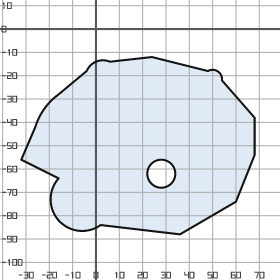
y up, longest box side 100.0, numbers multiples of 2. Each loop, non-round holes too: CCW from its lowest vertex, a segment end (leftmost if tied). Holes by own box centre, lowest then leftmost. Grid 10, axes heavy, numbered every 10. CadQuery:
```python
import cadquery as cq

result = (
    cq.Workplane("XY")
    .moveTo(36.0, -88.0)
    .lineTo(60.0, -74.0)
    .lineTo(68.0, -54.0)
    .lineTo(68.0, -38.0)
    .lineTo(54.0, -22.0)
    .threePointArc((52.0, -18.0), (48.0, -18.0))
    .lineTo(24.0, -12.0)
    .lineTo(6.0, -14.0)
    .threePointArc((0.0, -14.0), (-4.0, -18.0))
    .lineTo(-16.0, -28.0)
    .threePointArc((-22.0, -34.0), (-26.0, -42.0))
    .lineTo(-32.0, -56.0)
    .lineTo(-16.0, -64.0)
    .threePointArc((-16.0, -82.0), (2.0, -84.0))
    .close()
    .moveTo(28.0, -62.0)
    .circle(6.0)
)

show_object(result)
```